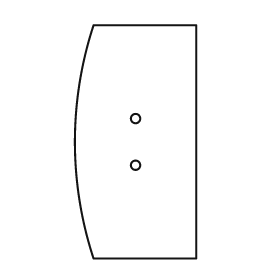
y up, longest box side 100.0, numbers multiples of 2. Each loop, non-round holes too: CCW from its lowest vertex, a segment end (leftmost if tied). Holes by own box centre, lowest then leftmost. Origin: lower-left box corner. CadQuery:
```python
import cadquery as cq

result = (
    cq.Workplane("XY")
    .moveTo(8.0, 0.0)
    .lineTo(52.0, 0.0)
    .lineTo(52.0, 100.0)
    .lineTo(8.0, 100.0)
    .threePointArc((0.0, 50.0), (8.0, 0.0))
    .close()
    .moveTo(26.0, 40.0)
    .circle(2.0)
    .moveTo(26.0, 60.0)
    .circle(2.0)
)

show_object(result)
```